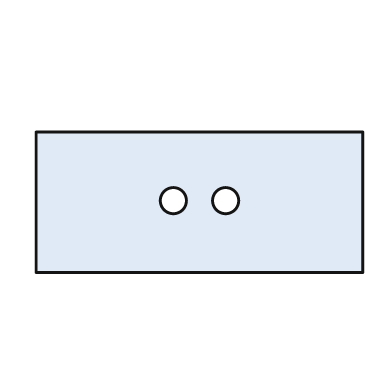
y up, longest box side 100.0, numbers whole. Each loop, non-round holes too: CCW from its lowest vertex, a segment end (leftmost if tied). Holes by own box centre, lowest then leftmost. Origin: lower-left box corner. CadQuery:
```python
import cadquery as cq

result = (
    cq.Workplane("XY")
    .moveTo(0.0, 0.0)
    .lineTo(100.0, 0.0)
    .lineTo(100.0, 43.0)
    .lineTo(0.0, 43.0)
    .close()
    .moveTo(42.0, 22.0)
    .circle(4.0)
    .moveTo(58.0, 22.0)
    .circle(4.0)
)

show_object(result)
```